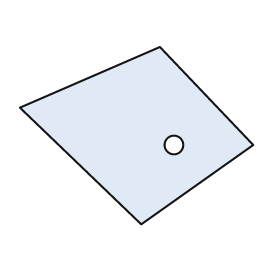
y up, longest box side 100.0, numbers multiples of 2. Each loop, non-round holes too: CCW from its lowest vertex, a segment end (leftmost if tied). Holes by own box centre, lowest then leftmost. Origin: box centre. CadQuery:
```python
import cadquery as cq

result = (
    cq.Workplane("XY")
    .moveTo(2.0, -38.0)
    .lineTo(50.0, -4.0)
    .lineTo(10.0, 38.0)
    .lineTo(-50.0, 12.0)
    .close()
    .moveTo(16.0, -4.0)
    .circle(4.0)
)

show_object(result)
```